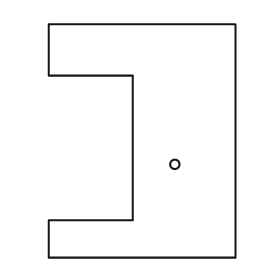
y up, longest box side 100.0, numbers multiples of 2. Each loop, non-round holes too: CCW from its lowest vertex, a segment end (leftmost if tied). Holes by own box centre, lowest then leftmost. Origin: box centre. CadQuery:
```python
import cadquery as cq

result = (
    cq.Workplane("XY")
    .moveTo(-40.0, -50.0)
    .lineTo(40.0, -50.0)
    .lineTo(40.0, 50.0)
    .lineTo(-40.0, 50.0)
    .lineTo(-40.0, 28.0)
    .lineTo(-4.0, 28.0)
    .lineTo(-4.0, -34.0)
    .lineTo(-40.0, -34.0)
    .close()
    .moveTo(14.0, -10.0)
    .circle(2.0)
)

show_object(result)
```